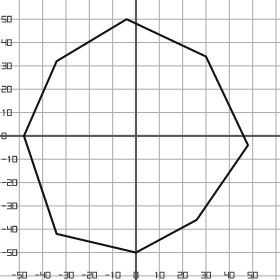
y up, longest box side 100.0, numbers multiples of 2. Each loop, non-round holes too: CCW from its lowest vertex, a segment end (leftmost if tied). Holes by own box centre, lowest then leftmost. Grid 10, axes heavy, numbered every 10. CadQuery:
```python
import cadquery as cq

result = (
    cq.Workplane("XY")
    .moveTo(0.0, -50.0)
    .lineTo(26.0, -36.0)
    .lineTo(48.0, -4.0)
    .lineTo(30.0, 34.0)
    .lineTo(-4.0, 50.0)
    .lineTo(-34.0, 32.0)
    .lineTo(-48.0, 0.0)
    .lineTo(-34.0, -42.0)
    .close()
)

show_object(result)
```